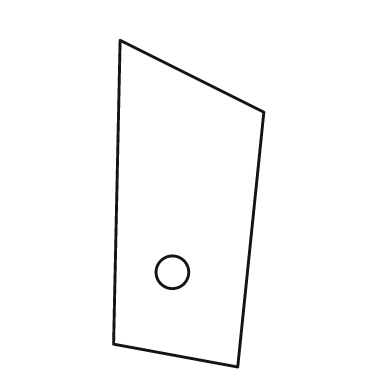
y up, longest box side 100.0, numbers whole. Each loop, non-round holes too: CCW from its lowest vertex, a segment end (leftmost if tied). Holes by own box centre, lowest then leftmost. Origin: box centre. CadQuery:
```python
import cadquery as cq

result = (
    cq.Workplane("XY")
    .moveTo(15.0, -50.0)
    .lineTo(23.0, 28.0)
    .lineTo(-21.0, 50.0)
    .lineTo(-23.0, -43.0)
    .close()
    .moveTo(-5.0, -21.0)
    .circle(5.0)
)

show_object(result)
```